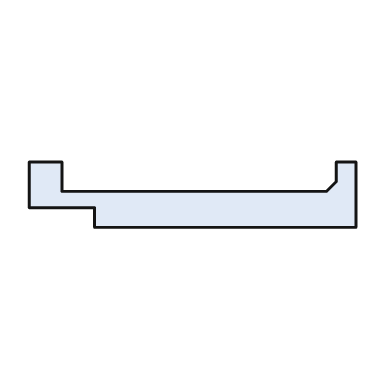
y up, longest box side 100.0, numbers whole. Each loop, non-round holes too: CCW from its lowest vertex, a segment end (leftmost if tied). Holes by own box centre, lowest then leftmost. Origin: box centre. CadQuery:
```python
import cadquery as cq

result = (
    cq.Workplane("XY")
    .moveTo(-30.0, -10.0)
    .lineTo(50.0, -10.0)
    .lineTo(50.0, 10.0)
    .lineTo(44.0, 10.0)
    .lineTo(44.0, 4.0)
    .lineTo(41.0, 1.0)
    .lineTo(-40.0, 1.0)
    .lineTo(-40.0, 10.0)
    .lineTo(-50.0, 10.0)
    .lineTo(-50.0, -4.0)
    .lineTo(-30.0, -4.0)
    .close()
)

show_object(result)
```